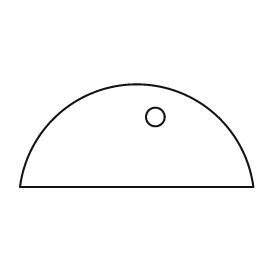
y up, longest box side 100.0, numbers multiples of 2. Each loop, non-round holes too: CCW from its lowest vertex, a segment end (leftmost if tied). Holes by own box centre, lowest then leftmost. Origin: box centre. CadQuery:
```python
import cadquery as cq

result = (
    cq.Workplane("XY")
    .moveTo(-50.0, -22.0)
    .lineTo(50.0, -22.0)
    .threePointArc((0.0, 22.0), (-50.0, -22.0))
    .close()
    .moveTo(8.0, 8.0)
    .circle(4.0)
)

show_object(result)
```